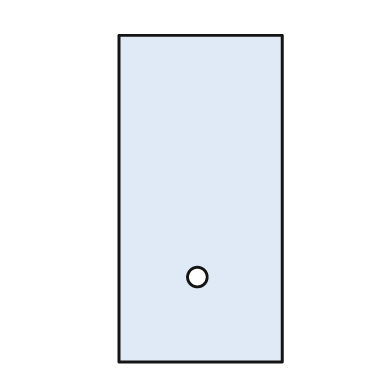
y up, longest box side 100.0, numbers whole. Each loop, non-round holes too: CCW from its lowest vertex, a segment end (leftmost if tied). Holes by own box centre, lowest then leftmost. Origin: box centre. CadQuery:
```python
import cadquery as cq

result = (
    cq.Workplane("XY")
    .moveTo(-25.0, -50.0)
    .lineTo(25.0, -50.0)
    .lineTo(25.0, 50.0)
    .lineTo(-25.0, 50.0)
    .close()
    .moveTo(-1.0, -24.0)
    .circle(3.0)
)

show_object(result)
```